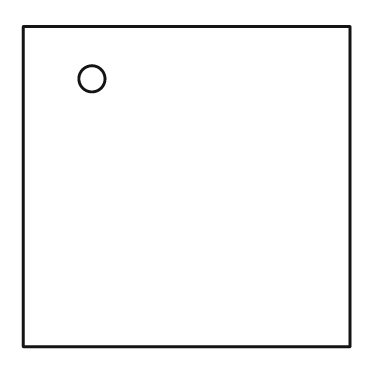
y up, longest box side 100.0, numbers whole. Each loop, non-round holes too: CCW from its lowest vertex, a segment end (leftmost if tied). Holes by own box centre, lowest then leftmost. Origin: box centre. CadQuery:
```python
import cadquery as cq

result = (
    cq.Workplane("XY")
    .moveTo(-50.0, -49.0)
    .lineTo(50.0, -49.0)
    .lineTo(50.0, 49.0)
    .lineTo(-50.0, 49.0)
    .close()
    .moveTo(-29.0, 33.0)
    .circle(4.0)
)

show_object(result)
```